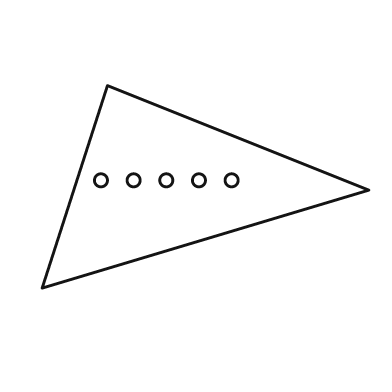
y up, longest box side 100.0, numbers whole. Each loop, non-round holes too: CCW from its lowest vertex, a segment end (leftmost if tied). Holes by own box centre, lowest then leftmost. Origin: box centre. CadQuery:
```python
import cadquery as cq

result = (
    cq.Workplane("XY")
    .moveTo(-50.0, -31.0)
    .lineTo(50.0, -1.0)
    .lineTo(-30.0, 31.0)
    .close()
    .moveTo(-32.0, 2.0)
    .circle(2.0)
    .moveTo(-22.0, 2.0)
    .circle(2.0)
    .moveTo(-12.0, 2.0)
    .circle(2.0)
    .moveTo(-2.0, 2.0)
    .circle(2.0)
    .moveTo(8.0, 2.0)
    .circle(2.0)
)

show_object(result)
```